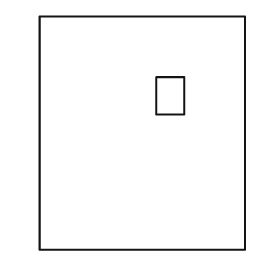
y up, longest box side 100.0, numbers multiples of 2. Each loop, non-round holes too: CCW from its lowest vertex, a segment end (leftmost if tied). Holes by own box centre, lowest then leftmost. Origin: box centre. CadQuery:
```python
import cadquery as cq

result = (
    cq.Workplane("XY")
    .moveTo(-44.0, -50.0)
    .lineTo(44.0, -50.0)
    .lineTo(44.0, 50.0)
    .lineTo(-44.0, 50.0)
    .close()
    .moveTo(6.0, 8.0)
    .lineTo(18.0, 8.0)
    .lineTo(18.0, 24.0)
    .lineTo(6.0, 24.0)
    .close()
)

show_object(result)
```